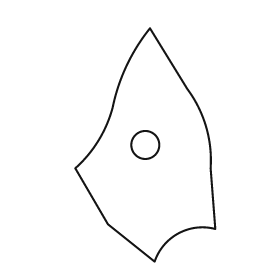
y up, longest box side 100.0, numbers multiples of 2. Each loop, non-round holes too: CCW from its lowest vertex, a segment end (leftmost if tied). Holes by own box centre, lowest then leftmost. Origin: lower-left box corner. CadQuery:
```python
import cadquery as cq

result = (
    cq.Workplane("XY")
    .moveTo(34.0, 0.0)
    .threePointArc((44.0, 12.0), (60.0, 14.0))
    .lineTo(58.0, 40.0)
    .threePointArc((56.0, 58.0), (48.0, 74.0))
    .lineTo(32.0, 100.0)
    .threePointArc((22.0, 84.0), (16.0, 66.0))
    .threePointArc((10.0, 52.0), (0.0, 40.0))
    .lineTo(14.0, 16.0)
    .close()
    .moveTo(30.0, 50.0)
    .circle(6.0)
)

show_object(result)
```